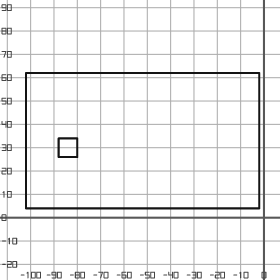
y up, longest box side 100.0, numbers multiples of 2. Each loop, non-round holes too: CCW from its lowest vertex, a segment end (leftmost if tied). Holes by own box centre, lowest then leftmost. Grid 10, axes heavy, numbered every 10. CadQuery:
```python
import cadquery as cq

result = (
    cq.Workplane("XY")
    .moveTo(-102.0, 4.0)
    .lineTo(-2.0, 4.0)
    .lineTo(-2.0, 62.0)
    .lineTo(-102.0, 62.0)
    .close()
    .moveTo(-88.0, 26.0)
    .lineTo(-80.0, 26.0)
    .lineTo(-80.0, 34.0)
    .lineTo(-88.0, 34.0)
    .close()
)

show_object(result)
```